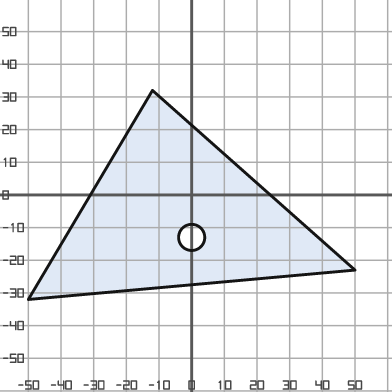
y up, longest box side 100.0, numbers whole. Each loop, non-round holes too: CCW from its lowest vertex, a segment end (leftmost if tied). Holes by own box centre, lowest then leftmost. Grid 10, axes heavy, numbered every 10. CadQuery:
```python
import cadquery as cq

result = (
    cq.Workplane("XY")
    .moveTo(-50.0, -32.0)
    .lineTo(50.0, -23.0)
    .lineTo(-12.0, 32.0)
    .close()
    .moveTo(0.0, -13.0)
    .circle(4.0)
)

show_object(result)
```